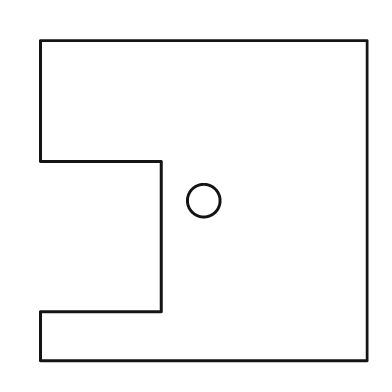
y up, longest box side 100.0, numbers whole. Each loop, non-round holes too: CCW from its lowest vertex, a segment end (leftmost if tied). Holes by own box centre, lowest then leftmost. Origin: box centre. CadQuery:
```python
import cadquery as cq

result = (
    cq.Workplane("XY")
    .moveTo(-50.0, -49.0)
    .lineTo(50.0, -49.0)
    .lineTo(50.0, 49.0)
    .lineTo(-50.0, 49.0)
    .lineTo(-50.0, 12.0)
    .lineTo(-13.0, 12.0)
    .lineTo(-13.0, -34.0)
    .lineTo(-50.0, -34.0)
    .close()
    .moveTo(0.0, 0.0)
    .circle(5.0)
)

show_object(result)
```